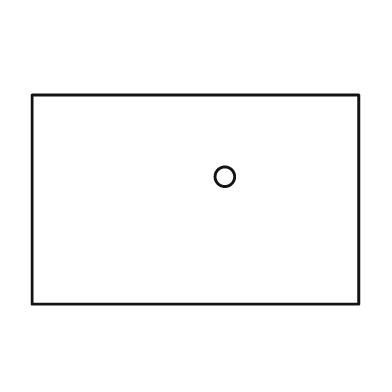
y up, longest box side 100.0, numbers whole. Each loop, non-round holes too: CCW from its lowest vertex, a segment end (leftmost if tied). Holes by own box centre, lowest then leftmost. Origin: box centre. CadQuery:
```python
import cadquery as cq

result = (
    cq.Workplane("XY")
    .moveTo(-50.0, -32.0)
    .lineTo(50.0, -32.0)
    .lineTo(50.0, 32.0)
    .lineTo(-50.0, 32.0)
    .close()
    .moveTo(9.0, 7.0)
    .circle(3.0)
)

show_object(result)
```